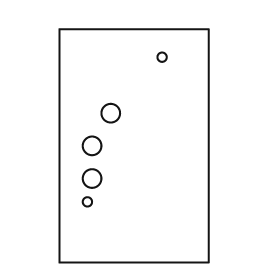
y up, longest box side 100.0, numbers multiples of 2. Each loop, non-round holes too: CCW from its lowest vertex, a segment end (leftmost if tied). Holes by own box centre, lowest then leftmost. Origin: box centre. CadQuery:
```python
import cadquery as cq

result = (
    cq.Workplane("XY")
    .moveTo(-32.0, -50.0)
    .lineTo(32.0, -50.0)
    .lineTo(32.0, 50.0)
    .lineTo(-32.0, 50.0)
    .close()
    .moveTo(-20.0, -24.0)
    .circle(2.0)
    .moveTo(-18.0, -14.0)
    .circle(4.0)
    .moveTo(-18.0, 0.0)
    .circle(4.0)
    .moveTo(-10.0, 14.0)
    .circle(4.0)
    .moveTo(12.0, 38.0)
    .circle(2.0)
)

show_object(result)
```